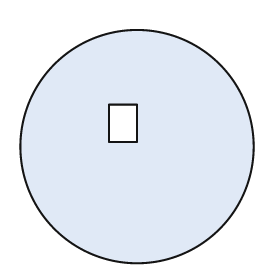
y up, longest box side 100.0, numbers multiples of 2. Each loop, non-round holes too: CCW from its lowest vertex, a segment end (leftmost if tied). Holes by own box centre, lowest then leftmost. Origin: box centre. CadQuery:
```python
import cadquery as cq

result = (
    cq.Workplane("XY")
    .moveTo(0.0, 0.0)
    .circle(50.0)
    .moveTo(-12.0, 2.0)
    .lineTo(0.0, 2.0)
    .lineTo(0.0, 18.0)
    .lineTo(-12.0, 18.0)
    .close()
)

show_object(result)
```